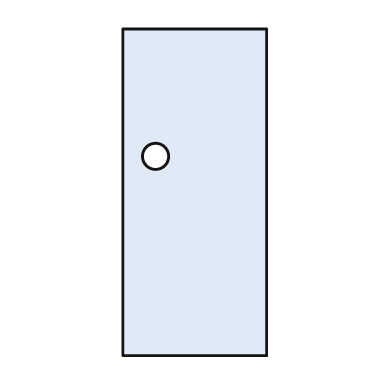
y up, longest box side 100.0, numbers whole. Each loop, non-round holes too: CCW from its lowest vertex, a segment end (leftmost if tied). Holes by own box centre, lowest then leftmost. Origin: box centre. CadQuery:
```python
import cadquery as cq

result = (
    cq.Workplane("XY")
    .moveTo(-22.0, -50.0)
    .lineTo(22.0, -50.0)
    .lineTo(22.0, 50.0)
    .lineTo(-22.0, 50.0)
    .close()
    .moveTo(-12.0, 11.0)
    .circle(4.0)
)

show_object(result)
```